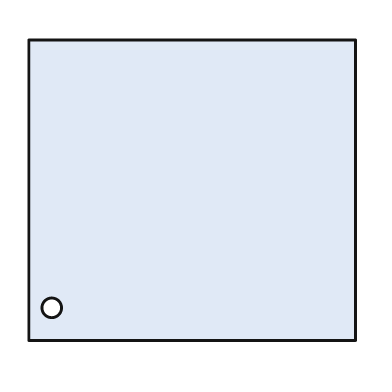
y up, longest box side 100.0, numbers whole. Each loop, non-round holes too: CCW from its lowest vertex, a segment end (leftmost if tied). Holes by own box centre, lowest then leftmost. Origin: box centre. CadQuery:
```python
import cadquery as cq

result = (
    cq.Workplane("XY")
    .moveTo(-50.0, -46.0)
    .lineTo(50.0, -46.0)
    .lineTo(50.0, 46.0)
    .lineTo(-50.0, 46.0)
    .close()
    .moveTo(-43.0, -36.0)
    .circle(3.0)
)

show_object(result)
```